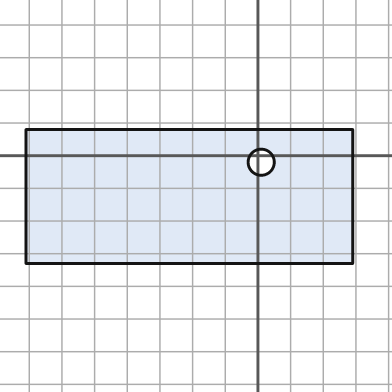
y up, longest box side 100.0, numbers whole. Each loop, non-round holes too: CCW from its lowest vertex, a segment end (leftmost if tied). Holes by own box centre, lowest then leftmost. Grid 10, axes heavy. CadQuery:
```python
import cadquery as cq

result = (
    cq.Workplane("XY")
    .moveTo(-71.0, -33.0)
    .lineTo(29.0, -33.0)
    .lineTo(29.0, 8.0)
    .lineTo(-71.0, 8.0)
    .close()
    .moveTo(1.0, -2.0)
    .circle(4.0)
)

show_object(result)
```